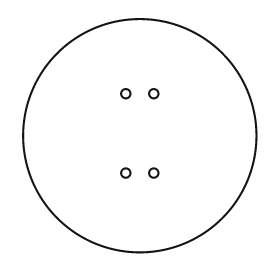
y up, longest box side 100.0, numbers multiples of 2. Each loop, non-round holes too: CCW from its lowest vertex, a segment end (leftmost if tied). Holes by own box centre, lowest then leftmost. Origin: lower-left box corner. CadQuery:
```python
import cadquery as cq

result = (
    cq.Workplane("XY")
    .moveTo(50.0, 50.0)
    .circle(50.0)
    .moveTo(44.0, 34.0)
    .circle(2.0)
    .moveTo(56.0, 34.0)
    .circle(2.0)
    .moveTo(44.0, 68.0)
    .circle(2.0)
    .moveTo(56.0, 68.0)
    .circle(2.0)
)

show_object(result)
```